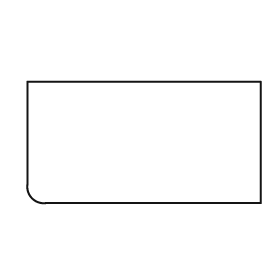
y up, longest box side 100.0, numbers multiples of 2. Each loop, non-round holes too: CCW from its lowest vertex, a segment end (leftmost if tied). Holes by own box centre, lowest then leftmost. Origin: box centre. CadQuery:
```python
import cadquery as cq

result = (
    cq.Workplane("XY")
    .moveTo(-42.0, -26.0)
    .lineTo(50.0, -26.0)
    .lineTo(50.0, 26.0)
    .lineTo(-50.0, 26.0)
    .lineTo(-50.0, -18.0)
    .threePointArc((-48.0, -24.0), (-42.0, -26.0))
    .close()
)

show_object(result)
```